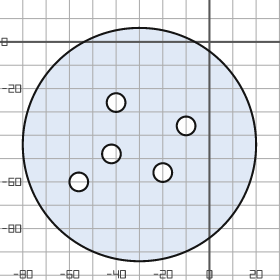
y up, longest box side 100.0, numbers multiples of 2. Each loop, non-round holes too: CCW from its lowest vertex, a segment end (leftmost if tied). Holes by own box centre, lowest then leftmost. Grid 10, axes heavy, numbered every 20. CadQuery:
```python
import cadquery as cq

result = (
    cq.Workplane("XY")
    .moveTo(-30.0, -44.0)
    .circle(50.0)
    .moveTo(-56.0, -60.0)
    .circle(4.0)
    .moveTo(-20.0, -56.0)
    .circle(4.0)
    .moveTo(-42.0, -48.0)
    .circle(4.0)
    .moveTo(-10.0, -36.0)
    .circle(4.0)
    .moveTo(-40.0, -26.0)
    .circle(4.0)
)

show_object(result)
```